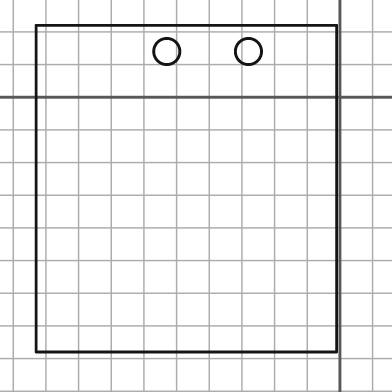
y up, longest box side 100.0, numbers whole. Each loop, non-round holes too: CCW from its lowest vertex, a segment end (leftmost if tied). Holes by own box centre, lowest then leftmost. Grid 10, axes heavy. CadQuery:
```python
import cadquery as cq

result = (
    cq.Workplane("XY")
    .moveTo(-93.0, -78.0)
    .lineTo(-1.0, -78.0)
    .lineTo(-1.0, 22.0)
    .lineTo(-93.0, 22.0)
    .close()
    .moveTo(-53.0, 14.0)
    .circle(4.0)
    .moveTo(-28.0, 14.0)
    .circle(4.0)
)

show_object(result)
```